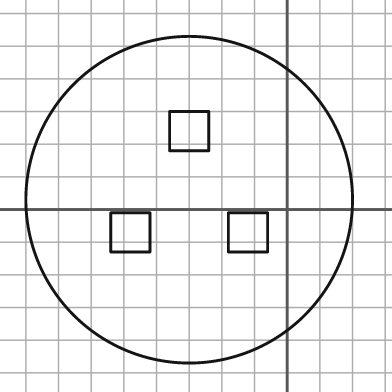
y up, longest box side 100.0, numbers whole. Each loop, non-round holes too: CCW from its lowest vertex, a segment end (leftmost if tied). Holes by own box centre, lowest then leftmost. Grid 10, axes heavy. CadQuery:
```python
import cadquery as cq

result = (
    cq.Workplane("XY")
    .moveTo(-30.0, 3.0)
    .circle(50.0)
    .moveTo(-54.0, -13.0)
    .lineTo(-42.0, -13.0)
    .lineTo(-42.0, -1.0)
    .lineTo(-54.0, -1.0)
    .close()
    .moveTo(-18.0, -13.0)
    .lineTo(-6.0, -13.0)
    .lineTo(-6.0, -1.0)
    .lineTo(-18.0, -1.0)
    .close()
    .moveTo(-36.0, 18.0)
    .lineTo(-24.0, 18.0)
    .lineTo(-24.0, 30.0)
    .lineTo(-36.0, 30.0)
    .close()
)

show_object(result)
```